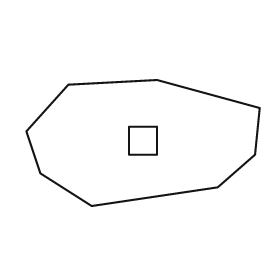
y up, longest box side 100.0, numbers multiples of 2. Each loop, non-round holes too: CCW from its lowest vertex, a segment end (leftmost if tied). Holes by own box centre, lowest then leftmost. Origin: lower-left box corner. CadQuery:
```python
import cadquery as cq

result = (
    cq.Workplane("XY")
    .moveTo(28.0, 0.0)
    .lineTo(82.0, 8.0)
    .lineTo(98.0, 22.0)
    .lineTo(100.0, 42.0)
    .lineTo(56.0, 54.0)
    .lineTo(18.0, 52.0)
    .lineTo(0.0, 32.0)
    .lineTo(6.0, 14.0)
    .close()
    .moveTo(44.0, 22.0)
    .lineTo(56.0, 22.0)
    .lineTo(56.0, 34.0)
    .lineTo(44.0, 34.0)
    .close()
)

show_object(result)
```